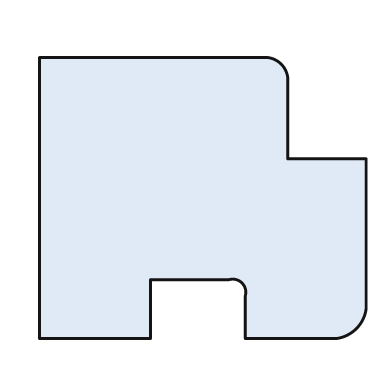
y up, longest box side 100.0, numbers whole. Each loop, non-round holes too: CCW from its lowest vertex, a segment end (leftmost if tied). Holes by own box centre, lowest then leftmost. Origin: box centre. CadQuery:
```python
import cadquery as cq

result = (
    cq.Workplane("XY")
    .moveTo(-50.0, -43.0)
    .lineTo(-16.0, -43.0)
    .lineTo(-16.0, -25.0)
    .lineTo(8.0, -25.0)
    .threePointArc((12.0, -26.0), (13.0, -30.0))
    .lineTo(13.0, -43.0)
    .lineTo(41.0, -43.0)
    .threePointArc((47.0, -40.0), (50.0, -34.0))
    .lineTo(50.0, 12.0)
    .lineTo(26.0, 12.0)
    .lineTo(26.0, 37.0)
    .threePointArc((24.0, 41.0), (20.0, 43.0))
    .lineTo(-50.0, 43.0)
    .close()
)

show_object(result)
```